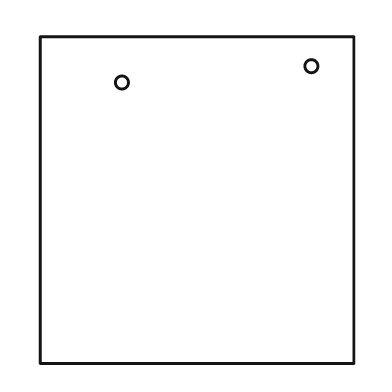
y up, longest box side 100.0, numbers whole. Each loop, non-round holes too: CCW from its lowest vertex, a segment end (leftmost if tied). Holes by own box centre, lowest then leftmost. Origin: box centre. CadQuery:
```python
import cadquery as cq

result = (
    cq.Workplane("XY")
    .moveTo(-48.0, -50.0)
    .lineTo(48.0, -50.0)
    .lineTo(48.0, 50.0)
    .lineTo(-48.0, 50.0)
    .close()
    .moveTo(-23.0, 36.0)
    .circle(2.0)
    .moveTo(35.0, 41.0)
    .circle(2.0)
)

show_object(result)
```